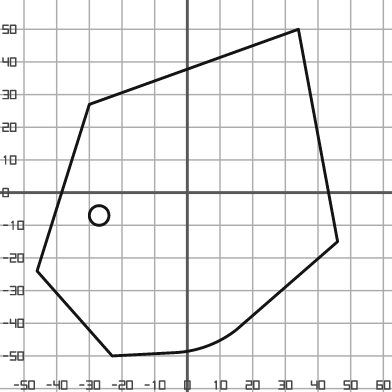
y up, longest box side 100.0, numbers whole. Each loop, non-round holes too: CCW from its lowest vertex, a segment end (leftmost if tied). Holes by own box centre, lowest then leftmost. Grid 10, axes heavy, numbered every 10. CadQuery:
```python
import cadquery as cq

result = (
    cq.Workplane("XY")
    .moveTo(-23.0, -50.0)
    .lineTo(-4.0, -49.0)
    .threePointArc((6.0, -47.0), (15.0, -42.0))
    .lineTo(46.0, -15.0)
    .lineTo(34.0, 50.0)
    .lineTo(-30.0, 27.0)
    .lineTo(-46.0, -24.0)
    .close()
    .moveTo(-27.0, -7.0)
    .circle(3.0)
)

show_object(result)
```